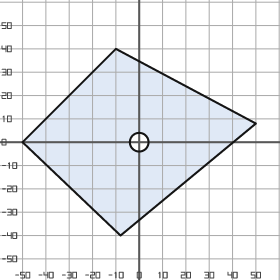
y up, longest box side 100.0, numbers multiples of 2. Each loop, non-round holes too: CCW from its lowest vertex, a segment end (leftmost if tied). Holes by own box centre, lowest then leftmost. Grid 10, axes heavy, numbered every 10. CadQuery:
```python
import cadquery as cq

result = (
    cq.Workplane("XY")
    .moveTo(-8.0, -40.0)
    .lineTo(50.0, 8.0)
    .lineTo(-10.0, 40.0)
    .lineTo(-50.0, 0.0)
    .close()
    .moveTo(0.0, 0.0)
    .circle(4.0)
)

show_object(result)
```